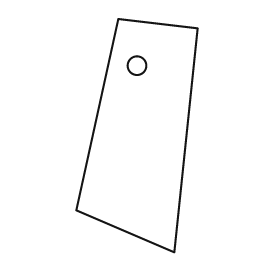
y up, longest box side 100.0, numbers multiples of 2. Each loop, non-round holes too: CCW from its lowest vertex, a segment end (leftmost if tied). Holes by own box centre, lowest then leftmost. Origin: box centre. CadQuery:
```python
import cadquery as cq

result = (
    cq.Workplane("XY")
    .moveTo(16.0, -50.0)
    .lineTo(26.0, 46.0)
    .lineTo(-8.0, 50.0)
    .lineTo(-26.0, -32.0)
    .close()
    .moveTo(0.0, 30.0)
    .circle(4.0)
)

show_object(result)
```